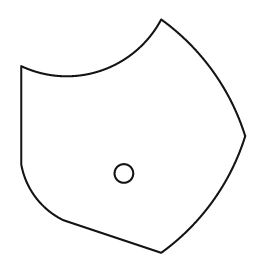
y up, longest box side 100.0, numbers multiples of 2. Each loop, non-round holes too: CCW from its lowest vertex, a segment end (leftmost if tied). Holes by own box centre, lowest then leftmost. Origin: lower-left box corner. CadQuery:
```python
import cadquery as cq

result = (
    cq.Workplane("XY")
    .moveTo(60.0, 0.0)
    .threePointArc((82.0, 22.0), (96.0, 50.0))
    .threePointArc((82.0, 78.0), (60.0, 100.0))
    .threePointArc((34.0, 78.0), (0.0, 80.0))
    .lineTo(0.0, 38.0)
    .threePointArc((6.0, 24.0), (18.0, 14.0))
    .close()
    .moveTo(44.0, 34.0)
    .circle(4.0)
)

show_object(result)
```